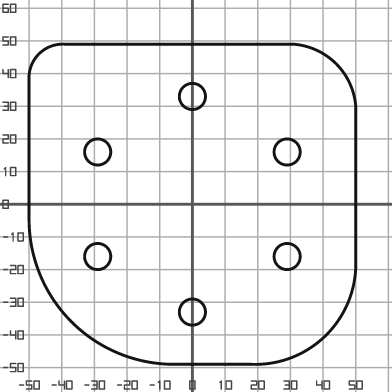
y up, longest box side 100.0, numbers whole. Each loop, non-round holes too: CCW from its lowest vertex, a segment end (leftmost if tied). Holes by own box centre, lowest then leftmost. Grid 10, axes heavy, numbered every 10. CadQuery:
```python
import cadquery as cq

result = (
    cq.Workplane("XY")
    .moveTo(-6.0, -49.0)
    .lineTo(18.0, -49.0)
    .threePointArc((41.0, -40.0), (50.0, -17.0))
    .lineTo(50.0, 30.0)
    .threePointArc((44.0, 43.0), (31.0, 49.0))
    .lineTo(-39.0, 49.0)
    .threePointArc((-47.0, 46.0), (-50.0, 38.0))
    .lineTo(-50.0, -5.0)
    .threePointArc((-37.0, -36.0), (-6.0, -49.0))
    .close()
    .moveTo(0.0, -33.0)
    .circle(4.0)
    .moveTo(-29.0, -16.0)
    .circle(4.0)
    .moveTo(29.0, -16.0)
    .circle(4.0)
    .moveTo(-29.0, 16.0)
    .circle(4.0)
    .moveTo(29.0, 16.0)
    .circle(4.0)
    .moveTo(0.0, 33.0)
    .circle(4.0)
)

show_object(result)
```